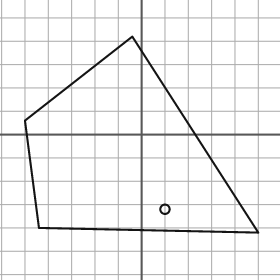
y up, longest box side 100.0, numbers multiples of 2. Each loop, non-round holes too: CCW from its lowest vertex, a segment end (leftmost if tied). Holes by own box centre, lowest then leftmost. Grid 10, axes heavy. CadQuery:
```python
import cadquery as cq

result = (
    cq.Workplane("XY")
    .moveTo(50.0, -42.0)
    .lineTo(-4.0, 42.0)
    .lineTo(-50.0, 6.0)
    .lineTo(-44.0, -40.0)
    .close()
    .moveTo(10.0, -32.0)
    .circle(2.0)
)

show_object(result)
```